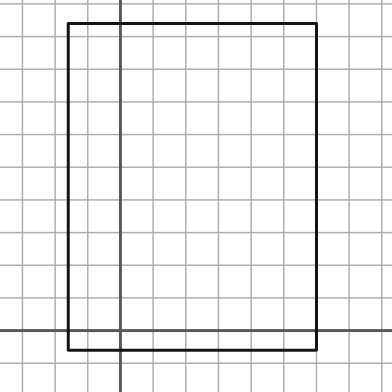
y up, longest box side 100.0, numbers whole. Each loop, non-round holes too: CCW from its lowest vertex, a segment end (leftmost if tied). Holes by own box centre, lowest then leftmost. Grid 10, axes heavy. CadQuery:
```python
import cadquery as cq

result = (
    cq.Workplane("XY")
    .moveTo(-16.0, -6.0)
    .lineTo(60.0, -6.0)
    .lineTo(60.0, 94.0)
    .lineTo(-16.0, 94.0)
    .close()
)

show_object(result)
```